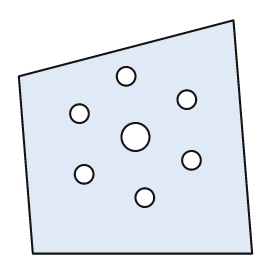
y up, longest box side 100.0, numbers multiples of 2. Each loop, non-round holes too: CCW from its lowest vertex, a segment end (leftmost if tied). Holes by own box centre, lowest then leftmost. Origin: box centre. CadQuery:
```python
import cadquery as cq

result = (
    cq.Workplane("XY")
    .moveTo(-44.0, -50.0)
    .lineTo(50.0, -50.0)
    .lineTo(42.0, 50.0)
    .lineTo(-50.0, 26.0)
    .close()
    .moveTo(4.0, -26.0)
    .circle(4.0)
    .moveTo(-22.0, -16.0)
    .circle(4.0)
    .moveTo(24.0, -10.0)
    .circle(4.0)
    .moveTo(0.0, 0.0)
    .circle(6.0)
    .moveTo(-24.0, 10.0)
    .circle(4.0)
    .moveTo(22.0, 16.0)
    .circle(4.0)
    .moveTo(-4.0, 26.0)
    .circle(4.0)
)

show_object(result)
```